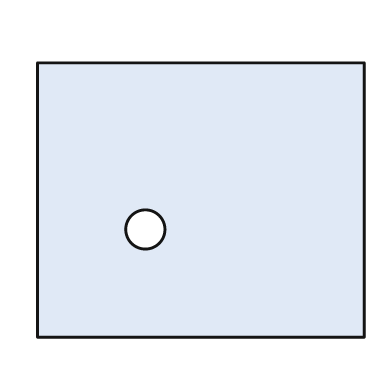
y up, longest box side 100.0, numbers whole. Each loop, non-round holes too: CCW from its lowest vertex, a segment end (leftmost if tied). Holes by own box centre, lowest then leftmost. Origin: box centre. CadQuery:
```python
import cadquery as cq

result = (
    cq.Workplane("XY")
    .moveTo(-50.0, -42.0)
    .lineTo(50.0, -42.0)
    .lineTo(50.0, 42.0)
    .lineTo(-50.0, 42.0)
    .close()
    .moveTo(-17.0, -9.0)
    .circle(6.0)
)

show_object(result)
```